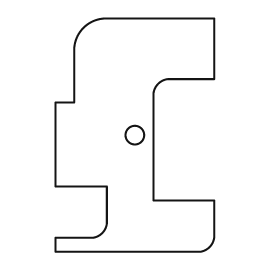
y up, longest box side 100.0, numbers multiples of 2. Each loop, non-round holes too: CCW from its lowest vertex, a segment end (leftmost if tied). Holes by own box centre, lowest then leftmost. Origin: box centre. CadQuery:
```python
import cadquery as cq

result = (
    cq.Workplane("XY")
    .moveTo(-34.0, -50.0)
    .lineTo(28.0, -50.0)
    .threePointArc((32.0, -48.0), (34.0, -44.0))
    .lineTo(34.0, -28.0)
    .lineTo(8.0, -28.0)
    .lineTo(8.0, 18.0)
    .threePointArc((10.0, 22.0), (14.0, 24.0))
    .lineTo(34.0, 24.0)
    .lineTo(34.0, 50.0)
    .lineTo(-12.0, 50.0)
    .threePointArc((-22.0, 46.0), (-26.0, 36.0))
    .lineTo(-26.0, 14.0)
    .lineTo(-34.0, 14.0)
    .lineTo(-34.0, -22.0)
    .lineTo(-12.0, -22.0)
    .lineTo(-12.0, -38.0)
    .threePointArc((-14.0, -42.0), (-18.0, -44.0))
    .lineTo(-34.0, -44.0)
    .close()
    .moveTo(0.0, 0.0)
    .circle(4.0)
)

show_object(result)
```